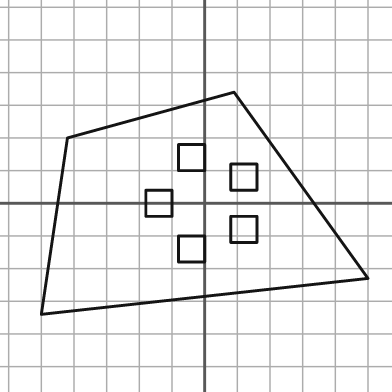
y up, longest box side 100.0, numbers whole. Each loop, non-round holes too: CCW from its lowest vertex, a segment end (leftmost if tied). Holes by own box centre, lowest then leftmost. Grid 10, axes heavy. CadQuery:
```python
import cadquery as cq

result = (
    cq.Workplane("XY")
    .moveTo(-50.0, -34.0)
    .lineTo(50.0, -23.0)
    .lineTo(9.0, 34.0)
    .lineTo(-42.0, 20.0)
    .close()
    .moveTo(-8.0, -18.0)
    .lineTo(0.0, -18.0)
    .lineTo(0.0, -10.0)
    .lineTo(-8.0, -10.0)
    .close()
    .moveTo(8.0, -12.0)
    .lineTo(16.0, -12.0)
    .lineTo(16.0, -4.0)
    .lineTo(8.0, -4.0)
    .close()
    .moveTo(-18.0, -4.0)
    .lineTo(-10.0, -4.0)
    .lineTo(-10.0, 4.0)
    .lineTo(-18.0, 4.0)
    .close()
    .moveTo(8.0, 4.0)
    .lineTo(16.0, 4.0)
    .lineTo(16.0, 12.0)
    .lineTo(8.0, 12.0)
    .close()
    .moveTo(-8.0, 10.0)
    .lineTo(0.0, 10.0)
    .lineTo(0.0, 18.0)
    .lineTo(-8.0, 18.0)
    .close()
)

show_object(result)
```